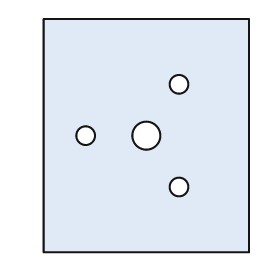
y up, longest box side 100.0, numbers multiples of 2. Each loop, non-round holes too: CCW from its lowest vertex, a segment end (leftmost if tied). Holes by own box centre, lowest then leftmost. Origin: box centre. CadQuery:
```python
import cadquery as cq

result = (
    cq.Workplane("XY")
    .moveTo(-44.0, -50.0)
    .lineTo(44.0, -50.0)
    .lineTo(44.0, 50.0)
    .lineTo(-44.0, 50.0)
    .close()
    .moveTo(14.0, -22.0)
    .circle(4.0)
    .moveTo(-26.0, 0.0)
    .circle(4.0)
    .moveTo(0.0, 0.0)
    .circle(6.0)
    .moveTo(14.0, 22.0)
    .circle(4.0)
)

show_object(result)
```